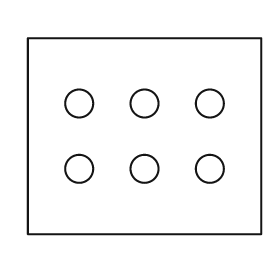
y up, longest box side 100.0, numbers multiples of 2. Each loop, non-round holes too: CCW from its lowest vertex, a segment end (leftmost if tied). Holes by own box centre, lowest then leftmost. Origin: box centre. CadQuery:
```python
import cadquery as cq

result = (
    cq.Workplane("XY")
    .moveTo(-50.0, -42.0)
    .lineTo(50.0, -42.0)
    .lineTo(50.0, 42.0)
    .lineTo(-50.0, 42.0)
    .close()
    .moveTo(-28.0, -14.0)
    .circle(6.0)
    .moveTo(0.0, -14.0)
    .circle(6.0)
    .moveTo(28.0, -14.0)
    .circle(6.0)
    .moveTo(-28.0, 14.0)
    .circle(6.0)
    .moveTo(0.0, 14.0)
    .circle(6.0)
    .moveTo(28.0, 14.0)
    .circle(6.0)
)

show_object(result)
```